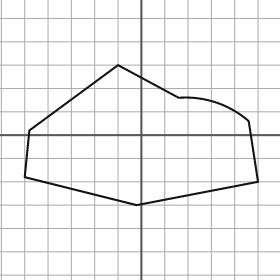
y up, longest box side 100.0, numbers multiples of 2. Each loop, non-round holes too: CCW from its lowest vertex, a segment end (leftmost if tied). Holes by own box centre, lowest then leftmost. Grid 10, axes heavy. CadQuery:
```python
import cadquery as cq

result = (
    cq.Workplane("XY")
    .moveTo(-2.0, -30.0)
    .lineTo(50.0, -20.0)
    .lineTo(46.0, 6.0)
    .threePointArc((32.0, 14.0), (16.0, 16.0))
    .lineTo(-10.0, 30.0)
    .lineTo(-48.0, 2.0)
    .lineTo(-50.0, -18.0)
    .close()
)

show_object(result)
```